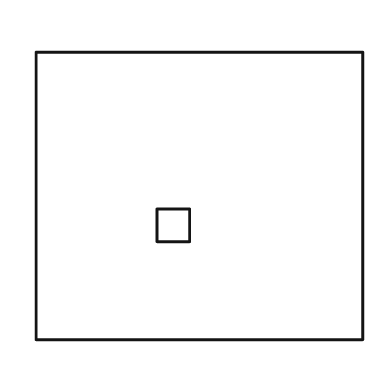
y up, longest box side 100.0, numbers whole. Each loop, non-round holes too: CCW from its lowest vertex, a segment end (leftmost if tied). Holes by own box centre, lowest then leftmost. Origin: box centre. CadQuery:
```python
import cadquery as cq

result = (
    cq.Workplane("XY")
    .moveTo(-50.0, -44.0)
    .lineTo(50.0, -44.0)
    .lineTo(50.0, 44.0)
    .lineTo(-50.0, 44.0)
    .close()
    .moveTo(-13.0, -14.0)
    .lineTo(-3.0, -14.0)
    .lineTo(-3.0, -4.0)
    .lineTo(-13.0, -4.0)
    .close()
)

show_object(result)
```